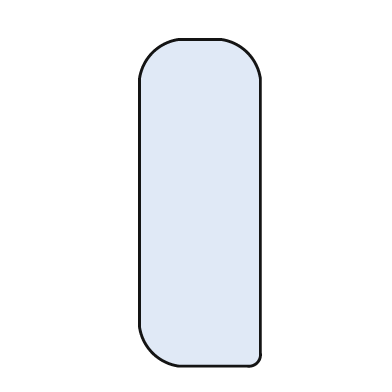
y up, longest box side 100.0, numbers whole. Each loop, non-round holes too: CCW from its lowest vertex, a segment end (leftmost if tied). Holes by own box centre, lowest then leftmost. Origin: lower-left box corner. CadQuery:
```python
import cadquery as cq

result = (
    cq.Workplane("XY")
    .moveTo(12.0, 0.0)
    .lineTo(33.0, 0.0)
    .threePointArc((36.0, 1.0), (37.0, 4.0))
    .lineTo(37.0, 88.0)
    .threePointArc((33.0, 96.0), (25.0, 100.0))
    .lineTo(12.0, 100.0)
    .threePointArc((4.0, 96.0), (0.0, 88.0))
    .lineTo(0.0, 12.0)
    .threePointArc((4.0, 4.0), (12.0, 0.0))
    .close()
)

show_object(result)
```